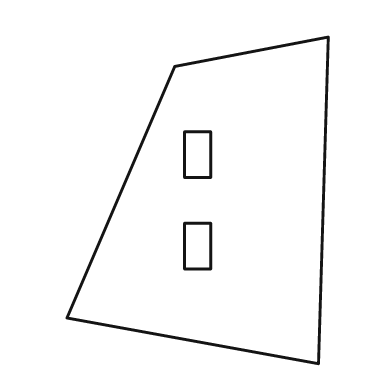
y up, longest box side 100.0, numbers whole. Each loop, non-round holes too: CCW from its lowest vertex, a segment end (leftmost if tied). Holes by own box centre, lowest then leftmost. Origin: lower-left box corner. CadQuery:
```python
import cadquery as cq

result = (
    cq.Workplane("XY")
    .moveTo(77.0, 0.0)
    .lineTo(80.0, 100.0)
    .lineTo(33.0, 91.0)
    .lineTo(0.0, 14.0)
    .close()
    .moveTo(36.0, 29.0)
    .lineTo(44.0, 29.0)
    .lineTo(44.0, 43.0)
    .lineTo(36.0, 43.0)
    .close()
    .moveTo(36.0, 57.0)
    .lineTo(44.0, 57.0)
    .lineTo(44.0, 71.0)
    .lineTo(36.0, 71.0)
    .close()
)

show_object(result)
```